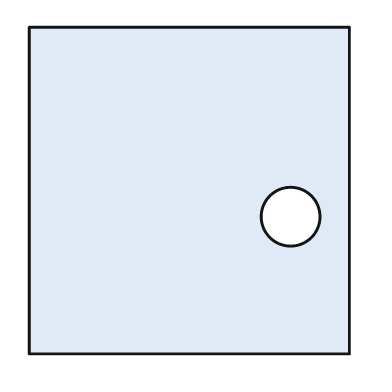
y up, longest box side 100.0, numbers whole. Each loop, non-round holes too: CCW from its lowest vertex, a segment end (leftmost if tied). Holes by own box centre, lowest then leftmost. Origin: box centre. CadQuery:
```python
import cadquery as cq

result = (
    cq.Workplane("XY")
    .moveTo(-49.0, -50.0)
    .lineTo(49.0, -50.0)
    .lineTo(49.0, 50.0)
    .lineTo(-49.0, 50.0)
    .close()
    .moveTo(31.0, -8.0)
    .circle(9.0)
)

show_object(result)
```